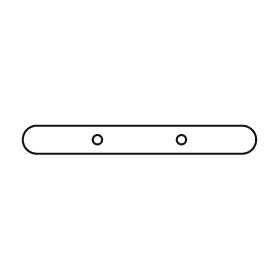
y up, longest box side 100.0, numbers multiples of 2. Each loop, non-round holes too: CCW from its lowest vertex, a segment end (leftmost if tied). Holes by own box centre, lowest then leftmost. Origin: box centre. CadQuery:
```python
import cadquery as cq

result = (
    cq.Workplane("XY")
    .moveTo(-44.0, -6.0)
    .lineTo(44.0, -6.0)
    .threePointArc((50.0, 0.0), (44.0, 6.0))
    .lineTo(-44.0, 6.0)
    .threePointArc((-50.0, 0.0), (-44.0, -6.0))
    .close()
    .moveTo(-18.0, 0.0)
    .circle(2.0)
    .moveTo(18.0, 0.0)
    .circle(2.0)
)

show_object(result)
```